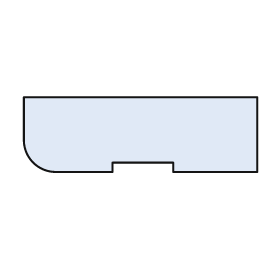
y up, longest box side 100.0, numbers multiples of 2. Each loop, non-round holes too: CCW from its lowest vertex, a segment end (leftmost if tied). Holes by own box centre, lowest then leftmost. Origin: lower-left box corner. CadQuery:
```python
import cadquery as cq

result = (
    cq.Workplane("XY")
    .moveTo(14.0, 0.0)
    .lineTo(38.0, 0.0)
    .lineTo(38.0, 4.0)
    .lineTo(64.0, 4.0)
    .lineTo(64.0, 0.0)
    .lineTo(100.0, 0.0)
    .lineTo(100.0, 32.0)
    .lineTo(0.0, 32.0)
    .lineTo(0.0, 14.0)
    .threePointArc((4.0, 4.0), (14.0, 0.0))
    .close()
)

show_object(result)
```